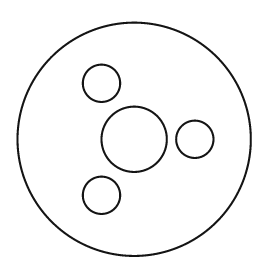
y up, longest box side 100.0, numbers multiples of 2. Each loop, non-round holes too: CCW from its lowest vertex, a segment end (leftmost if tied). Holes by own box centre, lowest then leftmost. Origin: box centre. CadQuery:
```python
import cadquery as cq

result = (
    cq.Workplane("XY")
    .moveTo(0.0, 0.0)
    .circle(50.0)
    .moveTo(-14.0, -24.0)
    .circle(8.0)
    .moveTo(0.0, 0.0)
    .circle(14.0)
    .moveTo(26.0, 0.0)
    .circle(8.0)
    .moveTo(-14.0, 24.0)
    .circle(8.0)
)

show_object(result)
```